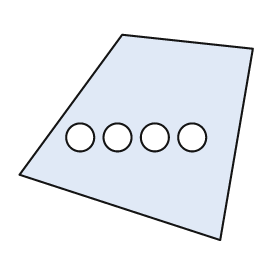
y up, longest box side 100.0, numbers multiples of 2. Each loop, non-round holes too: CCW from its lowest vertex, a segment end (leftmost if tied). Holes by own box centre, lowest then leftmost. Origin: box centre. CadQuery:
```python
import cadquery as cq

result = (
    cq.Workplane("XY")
    .moveTo(36.0, -44.0)
    .lineTo(50.0, 38.0)
    .lineTo(-6.0, 44.0)
    .lineTo(-50.0, -16.0)
    .close()
    .moveTo(-24.0, 0.0)
    .circle(6.0)
    .moveTo(-8.0, 0.0)
    .circle(6.0)
    .moveTo(8.0, 0.0)
    .circle(6.0)
    .moveTo(24.0, 0.0)
    .circle(6.0)
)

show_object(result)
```